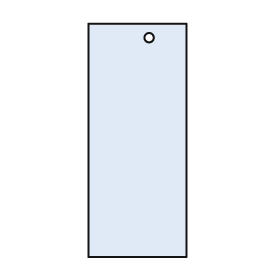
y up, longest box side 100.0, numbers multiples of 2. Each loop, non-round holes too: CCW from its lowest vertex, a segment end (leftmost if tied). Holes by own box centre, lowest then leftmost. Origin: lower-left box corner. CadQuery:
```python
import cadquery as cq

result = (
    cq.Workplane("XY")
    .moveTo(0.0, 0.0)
    .lineTo(42.0, 0.0)
    .lineTo(42.0, 100.0)
    .lineTo(0.0, 100.0)
    .close()
    .moveTo(26.0, 94.0)
    .circle(2.0)
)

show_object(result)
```